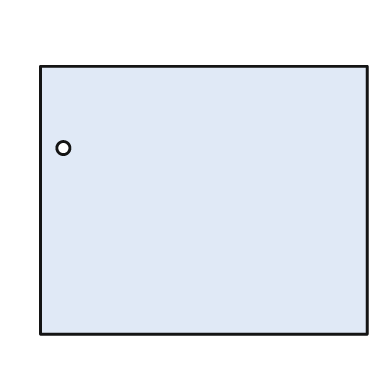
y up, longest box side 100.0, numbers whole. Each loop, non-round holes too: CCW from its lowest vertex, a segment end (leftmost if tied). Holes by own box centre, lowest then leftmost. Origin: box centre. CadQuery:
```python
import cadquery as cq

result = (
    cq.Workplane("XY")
    .moveTo(-50.0, -41.0)
    .lineTo(50.0, -41.0)
    .lineTo(50.0, 41.0)
    .lineTo(-50.0, 41.0)
    .close()
    .moveTo(-43.0, 16.0)
    .circle(2.0)
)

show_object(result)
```